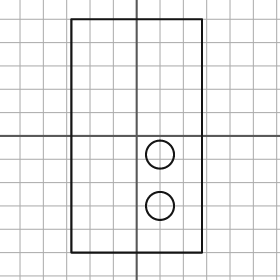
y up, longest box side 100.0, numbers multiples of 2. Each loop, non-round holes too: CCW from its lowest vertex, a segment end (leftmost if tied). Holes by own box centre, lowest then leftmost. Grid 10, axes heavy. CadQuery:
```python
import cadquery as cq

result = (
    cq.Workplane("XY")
    .moveTo(-28.0, -50.0)
    .lineTo(28.0, -50.0)
    .lineTo(28.0, 50.0)
    .lineTo(-28.0, 50.0)
    .close()
    .moveTo(10.0, -30.0)
    .circle(6.0)
    .moveTo(10.0, -8.0)
    .circle(6.0)
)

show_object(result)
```